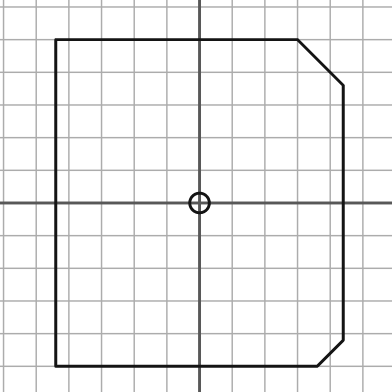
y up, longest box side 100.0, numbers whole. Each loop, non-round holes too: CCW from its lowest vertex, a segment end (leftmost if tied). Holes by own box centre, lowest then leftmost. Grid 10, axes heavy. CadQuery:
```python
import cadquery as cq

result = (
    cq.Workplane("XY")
    .moveTo(-44.0, -50.0)
    .lineTo(36.0, -50.0)
    .lineTo(44.0, -42.0)
    .lineTo(44.0, 36.0)
    .lineTo(30.0, 50.0)
    .lineTo(-44.0, 50.0)
    .close()
    .moveTo(0.0, 0.0)
    .circle(3.0)
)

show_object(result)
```